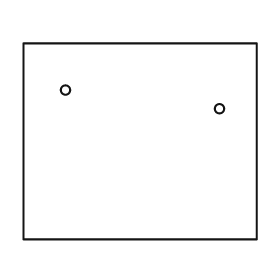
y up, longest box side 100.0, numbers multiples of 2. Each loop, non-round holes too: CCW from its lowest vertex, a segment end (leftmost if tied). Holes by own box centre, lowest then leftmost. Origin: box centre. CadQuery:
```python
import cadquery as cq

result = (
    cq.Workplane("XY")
    .moveTo(-50.0, -42.0)
    .lineTo(50.0, -42.0)
    .lineTo(50.0, 42.0)
    .lineTo(-50.0, 42.0)
    .close()
    .moveTo(34.0, 14.0)
    .circle(2.0)
    .moveTo(-32.0, 22.0)
    .circle(2.0)
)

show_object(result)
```